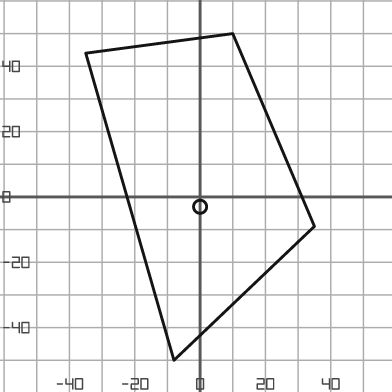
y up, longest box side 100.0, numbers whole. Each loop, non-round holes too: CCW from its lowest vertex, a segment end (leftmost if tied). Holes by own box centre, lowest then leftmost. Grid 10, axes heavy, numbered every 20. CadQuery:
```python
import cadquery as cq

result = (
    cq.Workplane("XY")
    .moveTo(-8.0, -50.0)
    .lineTo(35.0, -9.0)
    .lineTo(10.0, 50.0)
    .lineTo(-35.0, 44.0)
    .close()
    .moveTo(0.0, -3.0)
    .circle(2.0)
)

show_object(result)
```